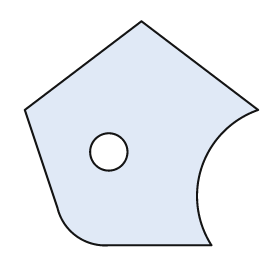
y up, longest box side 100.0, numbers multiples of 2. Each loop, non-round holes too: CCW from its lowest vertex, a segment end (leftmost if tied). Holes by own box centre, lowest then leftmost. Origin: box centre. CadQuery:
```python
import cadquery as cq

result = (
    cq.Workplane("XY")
    .moveTo(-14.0, -48.0)
    .lineTo(30.0, -48.0)
    .threePointArc((26.0, -14.0), (50.0, 10.0))
    .lineTo(0.0, 48.0)
    .lineTo(-50.0, 10.0)
    .lineTo(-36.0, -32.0)
    .threePointArc((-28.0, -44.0), (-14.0, -48.0))
    .close()
    .moveTo(-14.0, -8.0)
    .circle(8.0)
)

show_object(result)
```